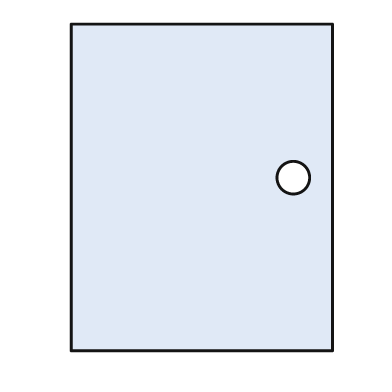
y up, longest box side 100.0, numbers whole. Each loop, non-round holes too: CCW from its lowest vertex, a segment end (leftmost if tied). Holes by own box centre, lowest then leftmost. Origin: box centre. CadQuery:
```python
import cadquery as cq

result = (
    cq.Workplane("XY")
    .moveTo(-40.0, -50.0)
    .lineTo(40.0, -50.0)
    .lineTo(40.0, 50.0)
    .lineTo(-40.0, 50.0)
    .close()
    .moveTo(28.0, 3.0)
    .circle(5.0)
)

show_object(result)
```